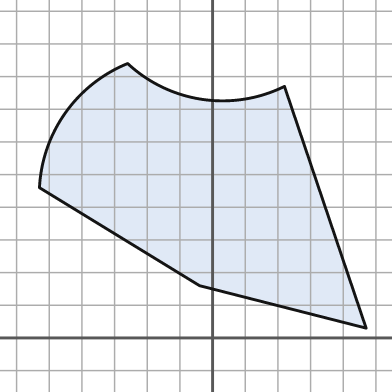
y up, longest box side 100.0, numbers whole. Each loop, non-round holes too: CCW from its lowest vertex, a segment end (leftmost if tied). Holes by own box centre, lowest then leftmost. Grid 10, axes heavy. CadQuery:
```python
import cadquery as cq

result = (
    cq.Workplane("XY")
    .moveTo(47.0, 3.0)
    .lineTo(22.0, 77.0)
    .threePointArc((-3.0, 73.0), (-26.0, 84.0))
    .threePointArc((-45.0, 69.0), (-53.0, 46.0))
    .lineTo(-4.0, 16.0)
    .close()
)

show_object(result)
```